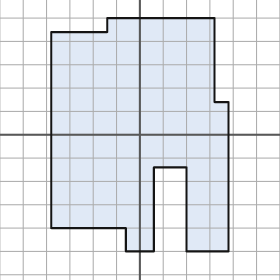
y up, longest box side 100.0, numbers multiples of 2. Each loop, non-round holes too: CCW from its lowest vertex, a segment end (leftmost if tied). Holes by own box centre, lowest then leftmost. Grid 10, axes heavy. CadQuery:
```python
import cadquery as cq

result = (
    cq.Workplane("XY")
    .moveTo(-6.0, -50.0)
    .lineTo(6.0, -50.0)
    .lineTo(6.0, -14.0)
    .lineTo(20.0, -14.0)
    .lineTo(20.0, -50.0)
    .lineTo(38.0, -50.0)
    .lineTo(38.0, 14.0)
    .lineTo(32.0, 14.0)
    .lineTo(32.0, 50.0)
    .lineTo(-14.0, 50.0)
    .lineTo(-14.0, 44.0)
    .lineTo(-38.0, 44.0)
    .lineTo(-38.0, -40.0)
    .lineTo(-6.0, -40.0)
    .close()
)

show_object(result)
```